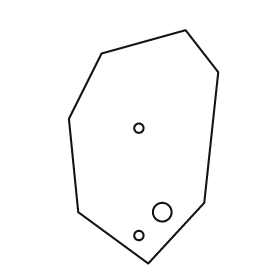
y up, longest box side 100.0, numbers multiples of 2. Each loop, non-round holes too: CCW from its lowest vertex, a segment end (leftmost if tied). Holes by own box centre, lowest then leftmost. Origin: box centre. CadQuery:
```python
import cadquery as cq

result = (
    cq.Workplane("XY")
    .moveTo(2.0, -50.0)
    .lineTo(26.0, -24.0)
    .lineTo(32.0, 32.0)
    .lineTo(18.0, 50.0)
    .lineTo(-18.0, 40.0)
    .lineTo(-32.0, 12.0)
    .lineTo(-28.0, -28.0)
    .close()
    .moveTo(-2.0, -38.0)
    .circle(2.0)
    .moveTo(8.0, -28.0)
    .circle(4.0)
    .moveTo(-2.0, 8.0)
    .circle(2.0)
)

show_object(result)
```